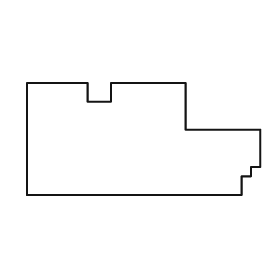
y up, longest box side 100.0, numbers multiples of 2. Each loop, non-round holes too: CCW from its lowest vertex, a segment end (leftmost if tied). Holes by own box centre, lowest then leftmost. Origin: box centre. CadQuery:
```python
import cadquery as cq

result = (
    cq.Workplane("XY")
    .moveTo(-50.0, -24.0)
    .lineTo(42.0, -24.0)
    .lineTo(42.0, -16.0)
    .lineTo(46.0, -16.0)
    .lineTo(46.0, -12.0)
    .lineTo(50.0, -12.0)
    .lineTo(50.0, 4.0)
    .lineTo(18.0, 4.0)
    .lineTo(18.0, 24.0)
    .lineTo(-14.0, 24.0)
    .lineTo(-14.0, 16.0)
    .lineTo(-24.0, 16.0)
    .lineTo(-24.0, 24.0)
    .lineTo(-50.0, 24.0)
    .close()
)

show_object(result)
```